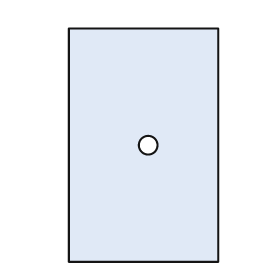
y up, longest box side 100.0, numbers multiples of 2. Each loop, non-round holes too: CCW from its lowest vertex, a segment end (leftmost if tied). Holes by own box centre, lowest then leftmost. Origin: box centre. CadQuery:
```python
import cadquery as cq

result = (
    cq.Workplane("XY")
    .moveTo(-32.0, -50.0)
    .lineTo(32.0, -50.0)
    .lineTo(32.0, 50.0)
    .lineTo(-32.0, 50.0)
    .close()
    .moveTo(2.0, 0.0)
    .circle(4.0)
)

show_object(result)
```